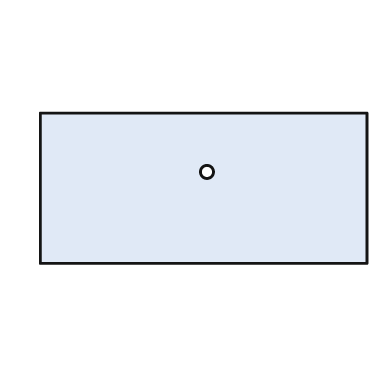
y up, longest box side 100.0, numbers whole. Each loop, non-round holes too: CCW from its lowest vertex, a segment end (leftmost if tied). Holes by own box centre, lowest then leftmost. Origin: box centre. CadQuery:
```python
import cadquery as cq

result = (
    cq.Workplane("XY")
    .moveTo(-50.0, -23.0)
    .lineTo(50.0, -23.0)
    .lineTo(50.0, 23.0)
    .lineTo(-50.0, 23.0)
    .close()
    .moveTo(1.0, 5.0)
    .circle(2.0)
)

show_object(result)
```